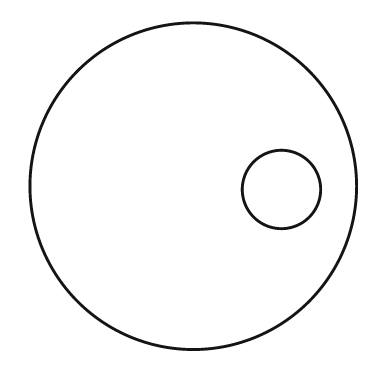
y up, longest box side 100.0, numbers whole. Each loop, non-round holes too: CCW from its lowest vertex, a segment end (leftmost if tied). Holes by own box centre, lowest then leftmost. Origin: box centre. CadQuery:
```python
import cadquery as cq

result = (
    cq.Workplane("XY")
    .moveTo(0.0, 0.0)
    .circle(50.0)
    .moveTo(27.0, -1.0)
    .circle(12.0)
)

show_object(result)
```